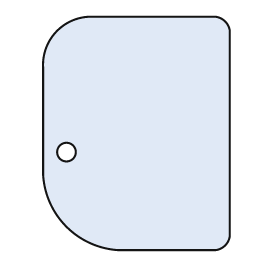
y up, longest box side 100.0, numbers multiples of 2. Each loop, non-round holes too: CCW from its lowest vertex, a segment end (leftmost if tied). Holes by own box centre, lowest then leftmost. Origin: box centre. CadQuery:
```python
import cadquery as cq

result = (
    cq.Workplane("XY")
    .moveTo(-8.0, -50.0)
    .lineTo(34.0, -50.0)
    .threePointArc((38.0, -48.0), (40.0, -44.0))
    .lineTo(40.0, 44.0)
    .threePointArc((38.0, 48.0), (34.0, 50.0))
    .lineTo(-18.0, 50.0)
    .threePointArc((-34.0, 44.0), (-40.0, 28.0))
    .lineTo(-40.0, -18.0)
    .threePointArc((-30.0, -40.0), (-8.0, -50.0))
    .close()
    .moveTo(-30.0, -8.0)
    .circle(4.0)
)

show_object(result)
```